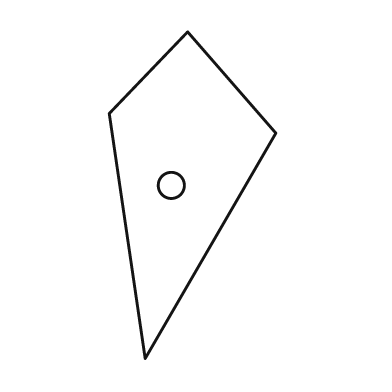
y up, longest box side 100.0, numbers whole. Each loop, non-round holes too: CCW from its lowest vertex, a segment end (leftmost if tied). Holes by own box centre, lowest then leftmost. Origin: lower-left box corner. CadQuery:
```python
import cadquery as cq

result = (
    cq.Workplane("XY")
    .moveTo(11.0, 0.0)
    .lineTo(51.0, 69.0)
    .lineTo(24.0, 100.0)
    .lineTo(0.0, 75.0)
    .close()
    .moveTo(19.0, 53.0)
    .circle(4.0)
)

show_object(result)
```